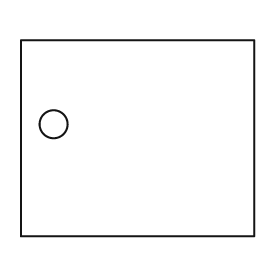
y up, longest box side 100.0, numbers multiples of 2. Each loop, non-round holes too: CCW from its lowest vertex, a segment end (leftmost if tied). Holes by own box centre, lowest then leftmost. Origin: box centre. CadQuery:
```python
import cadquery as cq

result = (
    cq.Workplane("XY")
    .moveTo(-50.0, -42.0)
    .lineTo(50.0, -42.0)
    .lineTo(50.0, 42.0)
    .lineTo(-50.0, 42.0)
    .close()
    .moveTo(-36.0, 6.0)
    .circle(6.0)
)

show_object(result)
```